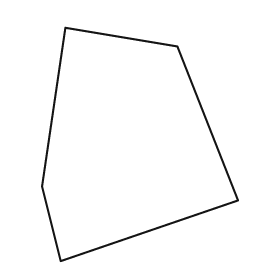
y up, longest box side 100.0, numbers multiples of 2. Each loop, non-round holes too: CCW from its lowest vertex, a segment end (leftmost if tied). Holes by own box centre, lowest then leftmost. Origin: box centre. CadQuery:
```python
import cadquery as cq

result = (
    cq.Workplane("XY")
    .moveTo(-34.0, -50.0)
    .lineTo(42.0, -24.0)
    .lineTo(16.0, 42.0)
    .lineTo(-32.0, 50.0)
    .lineTo(-42.0, -18.0)
    .close()
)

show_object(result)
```